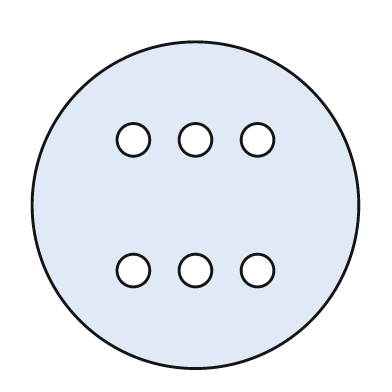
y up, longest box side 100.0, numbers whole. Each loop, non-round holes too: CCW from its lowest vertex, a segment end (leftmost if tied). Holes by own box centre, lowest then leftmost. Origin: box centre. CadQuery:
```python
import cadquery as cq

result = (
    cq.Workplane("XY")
    .moveTo(0.0, 0.0)
    .circle(50.0)
    .moveTo(-19.0, -20.0)
    .circle(5.0)
    .moveTo(0.0, -20.0)
    .circle(5.0)
    .moveTo(19.0, -20.0)
    .circle(5.0)
    .moveTo(-19.0, 20.0)
    .circle(5.0)
    .moveTo(0.0, 20.0)
    .circle(5.0)
    .moveTo(19.0, 20.0)
    .circle(5.0)
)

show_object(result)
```